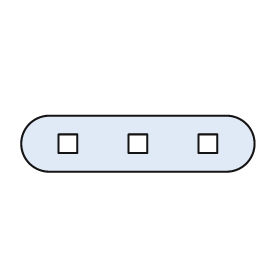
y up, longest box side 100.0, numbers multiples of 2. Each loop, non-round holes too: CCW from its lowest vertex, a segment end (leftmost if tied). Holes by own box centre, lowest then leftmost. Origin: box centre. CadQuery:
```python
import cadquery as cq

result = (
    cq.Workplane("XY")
    .moveTo(-38.0, -12.0)
    .lineTo(38.0, -12.0)
    .threePointArc((50.0, 0.0), (38.0, 12.0))
    .lineTo(-38.0, 12.0)
    .threePointArc((-50.0, 0.0), (-38.0, -12.0))
    .close()
    .moveTo(-34.0, -4.0)
    .lineTo(-26.0, -4.0)
    .lineTo(-26.0, 4.0)
    .lineTo(-34.0, 4.0)
    .close()
    .moveTo(-4.0, -4.0)
    .lineTo(4.0, -4.0)
    .lineTo(4.0, 4.0)
    .lineTo(-4.0, 4.0)
    .close()
    .moveTo(26.0, -4.0)
    .lineTo(34.0, -4.0)
    .lineTo(34.0, 4.0)
    .lineTo(26.0, 4.0)
    .close()
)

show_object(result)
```